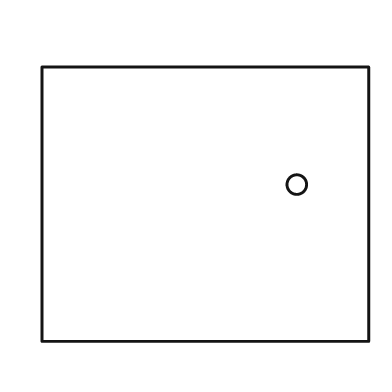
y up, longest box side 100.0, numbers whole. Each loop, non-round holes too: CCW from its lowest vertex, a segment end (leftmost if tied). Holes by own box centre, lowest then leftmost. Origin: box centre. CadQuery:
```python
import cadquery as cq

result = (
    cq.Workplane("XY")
    .moveTo(-50.0, -42.0)
    .lineTo(50.0, -42.0)
    .lineTo(50.0, 42.0)
    .lineTo(-50.0, 42.0)
    .close()
    .moveTo(28.0, 6.0)
    .circle(3.0)
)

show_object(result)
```